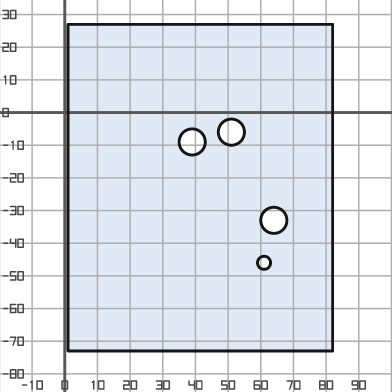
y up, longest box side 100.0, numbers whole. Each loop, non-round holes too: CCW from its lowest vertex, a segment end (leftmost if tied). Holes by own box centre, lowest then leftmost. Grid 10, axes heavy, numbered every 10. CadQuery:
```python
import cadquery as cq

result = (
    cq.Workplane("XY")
    .moveTo(1.0, -73.0)
    .lineTo(82.0, -73.0)
    .lineTo(82.0, 27.0)
    .lineTo(1.0, 27.0)
    .close()
    .moveTo(61.0, -46.0)
    .circle(2.0)
    .moveTo(64.0, -33.0)
    .circle(4.0)
    .moveTo(39.0, -9.0)
    .circle(4.0)
    .moveTo(51.0, -6.0)
    .circle(4.0)
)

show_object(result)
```